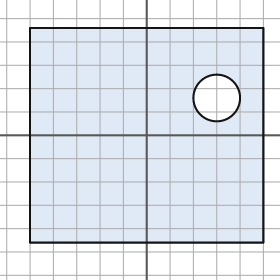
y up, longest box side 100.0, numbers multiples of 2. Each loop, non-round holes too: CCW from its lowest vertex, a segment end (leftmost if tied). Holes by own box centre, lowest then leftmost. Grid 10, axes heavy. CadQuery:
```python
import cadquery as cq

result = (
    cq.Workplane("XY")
    .moveTo(-50.0, -46.0)
    .lineTo(50.0, -46.0)
    .lineTo(50.0, 46.0)
    .lineTo(-50.0, 46.0)
    .close()
    .moveTo(30.0, 16.0)
    .circle(10.0)
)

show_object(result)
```